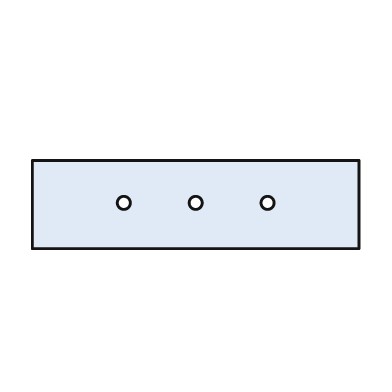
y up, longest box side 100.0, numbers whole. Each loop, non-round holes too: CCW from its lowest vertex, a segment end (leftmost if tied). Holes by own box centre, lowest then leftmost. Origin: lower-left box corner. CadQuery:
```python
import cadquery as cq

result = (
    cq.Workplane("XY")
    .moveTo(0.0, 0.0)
    .lineTo(100.0, 0.0)
    .lineTo(100.0, 27.0)
    .lineTo(0.0, 27.0)
    .close()
    .moveTo(28.0, 14.0)
    .circle(2.0)
    .moveTo(50.0, 14.0)
    .circle(2.0)
    .moveTo(72.0, 14.0)
    .circle(2.0)
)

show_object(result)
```